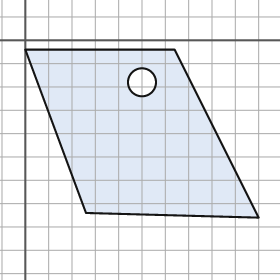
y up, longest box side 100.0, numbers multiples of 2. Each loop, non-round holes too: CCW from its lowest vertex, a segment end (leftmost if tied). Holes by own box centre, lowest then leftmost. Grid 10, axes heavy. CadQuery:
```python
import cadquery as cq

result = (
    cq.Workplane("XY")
    .moveTo(100.0, -76.0)
    .lineTo(64.0, -4.0)
    .lineTo(0.0, -4.0)
    .lineTo(26.0, -74.0)
    .close()
    .moveTo(50.0, -18.0)
    .circle(6.0)
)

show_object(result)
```